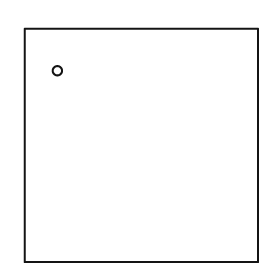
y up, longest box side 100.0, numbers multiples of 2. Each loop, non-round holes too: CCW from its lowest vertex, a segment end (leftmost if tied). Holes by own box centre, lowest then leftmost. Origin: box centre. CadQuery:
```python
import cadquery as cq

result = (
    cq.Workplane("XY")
    .moveTo(-50.0, -50.0)
    .lineTo(50.0, -50.0)
    .lineTo(50.0, 50.0)
    .lineTo(-50.0, 50.0)
    .close()
    .moveTo(-36.0, 32.0)
    .circle(2.0)
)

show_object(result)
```